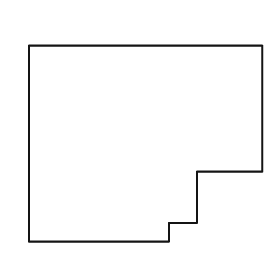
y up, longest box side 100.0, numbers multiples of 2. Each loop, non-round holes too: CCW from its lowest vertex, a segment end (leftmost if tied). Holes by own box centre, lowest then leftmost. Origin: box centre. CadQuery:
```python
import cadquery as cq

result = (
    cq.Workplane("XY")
    .moveTo(-50.0, -42.0)
    .lineTo(10.0, -42.0)
    .lineTo(10.0, -34.0)
    .lineTo(22.0, -34.0)
    .lineTo(22.0, -12.0)
    .lineTo(50.0, -12.0)
    .lineTo(50.0, 42.0)
    .lineTo(-50.0, 42.0)
    .close()
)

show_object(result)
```